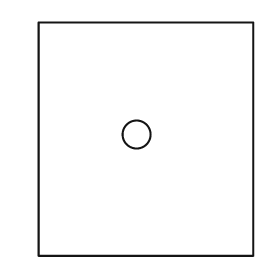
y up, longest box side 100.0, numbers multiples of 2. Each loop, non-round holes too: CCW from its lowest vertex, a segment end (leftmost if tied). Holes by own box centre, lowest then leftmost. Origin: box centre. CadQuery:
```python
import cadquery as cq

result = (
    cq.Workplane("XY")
    .moveTo(-46.0, -50.0)
    .lineTo(46.0, -50.0)
    .lineTo(46.0, 50.0)
    .lineTo(-46.0, 50.0)
    .close()
    .moveTo(-4.0, 2.0)
    .circle(6.0)
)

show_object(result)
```